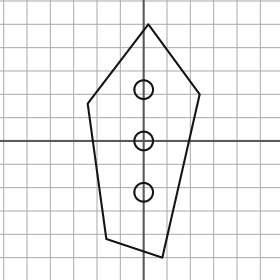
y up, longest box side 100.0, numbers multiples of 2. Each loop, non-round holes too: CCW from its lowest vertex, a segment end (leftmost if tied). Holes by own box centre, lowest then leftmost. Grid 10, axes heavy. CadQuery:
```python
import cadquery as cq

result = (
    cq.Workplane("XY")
    .moveTo(8.0, -50.0)
    .lineTo(24.0, 20.0)
    .lineTo(2.0, 50.0)
    .lineTo(-24.0, 16.0)
    .lineTo(-16.0, -42.0)
    .close()
    .moveTo(0.0, -22.0)
    .circle(4.0)
    .moveTo(0.0, 0.0)
    .circle(4.0)
    .moveTo(0.0, 22.0)
    .circle(4.0)
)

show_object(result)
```